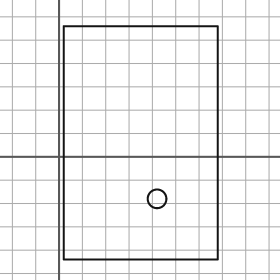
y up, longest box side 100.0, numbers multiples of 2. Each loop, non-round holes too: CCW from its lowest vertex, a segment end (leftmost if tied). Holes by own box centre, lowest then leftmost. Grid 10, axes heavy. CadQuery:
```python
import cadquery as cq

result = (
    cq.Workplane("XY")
    .moveTo(2.0, -44.0)
    .lineTo(68.0, -44.0)
    .lineTo(68.0, 56.0)
    .lineTo(2.0, 56.0)
    .close()
    .moveTo(42.0, -18.0)
    .circle(4.0)
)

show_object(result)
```